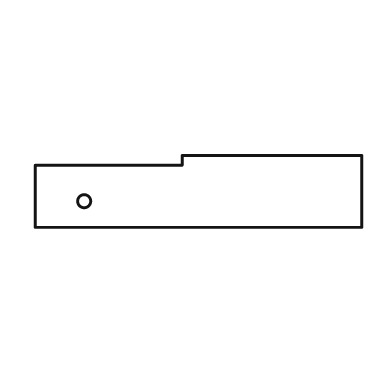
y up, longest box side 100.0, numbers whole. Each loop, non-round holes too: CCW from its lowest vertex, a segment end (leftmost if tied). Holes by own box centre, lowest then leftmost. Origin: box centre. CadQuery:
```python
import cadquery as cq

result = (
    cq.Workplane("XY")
    .moveTo(-50.0, -11.0)
    .lineTo(50.0, -11.0)
    .lineTo(50.0, 11.0)
    .lineTo(-5.0, 11.0)
    .lineTo(-5.0, 8.0)
    .lineTo(-50.0, 8.0)
    .close()
    .moveTo(-35.0, -3.0)
    .circle(2.0)
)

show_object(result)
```